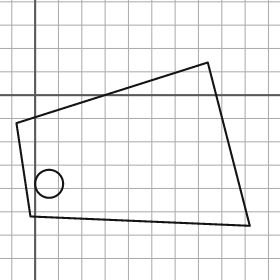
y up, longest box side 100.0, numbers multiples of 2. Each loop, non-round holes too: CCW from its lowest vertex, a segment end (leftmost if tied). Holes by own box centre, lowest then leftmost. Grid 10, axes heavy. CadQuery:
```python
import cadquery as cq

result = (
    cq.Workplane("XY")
    .moveTo(92.0, -56.0)
    .lineTo(74.0, 14.0)
    .lineTo(-8.0, -12.0)
    .lineTo(-2.0, -52.0)
    .close()
    .moveTo(6.0, -38.0)
    .circle(6.0)
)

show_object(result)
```